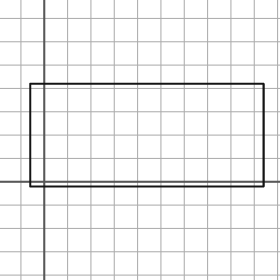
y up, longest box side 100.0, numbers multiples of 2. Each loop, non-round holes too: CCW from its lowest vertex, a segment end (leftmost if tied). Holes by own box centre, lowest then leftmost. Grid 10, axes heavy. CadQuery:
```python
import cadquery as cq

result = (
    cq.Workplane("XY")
    .moveTo(-6.0, -2.0)
    .lineTo(94.0, -2.0)
    .lineTo(94.0, 42.0)
    .lineTo(-6.0, 42.0)
    .close()
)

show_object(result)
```